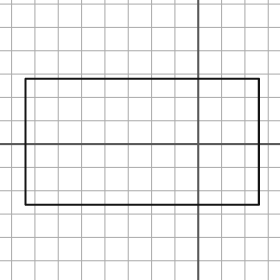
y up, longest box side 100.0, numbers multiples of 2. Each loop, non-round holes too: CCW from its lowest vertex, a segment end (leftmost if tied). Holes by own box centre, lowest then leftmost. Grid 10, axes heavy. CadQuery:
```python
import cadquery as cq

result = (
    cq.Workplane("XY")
    .moveTo(-74.0, -26.0)
    .lineTo(26.0, -26.0)
    .lineTo(26.0, 28.0)
    .lineTo(-74.0, 28.0)
    .close()
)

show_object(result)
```